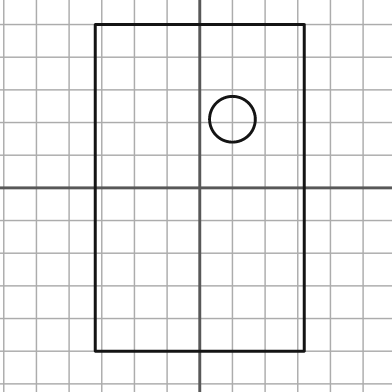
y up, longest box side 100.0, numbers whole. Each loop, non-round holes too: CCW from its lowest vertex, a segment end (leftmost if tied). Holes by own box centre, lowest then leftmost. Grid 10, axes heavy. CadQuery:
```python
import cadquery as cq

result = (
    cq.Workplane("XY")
    .moveTo(-32.0, -50.0)
    .lineTo(32.0, -50.0)
    .lineTo(32.0, 50.0)
    .lineTo(-32.0, 50.0)
    .close()
    .moveTo(10.0, 21.0)
    .circle(7.0)
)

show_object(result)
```